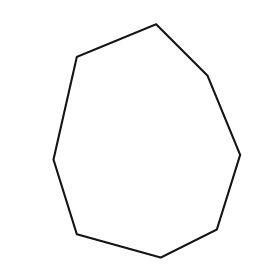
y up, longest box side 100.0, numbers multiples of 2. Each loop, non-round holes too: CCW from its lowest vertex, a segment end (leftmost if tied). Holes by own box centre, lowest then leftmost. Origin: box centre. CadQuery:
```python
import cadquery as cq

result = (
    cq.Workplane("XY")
    .moveTo(6.0, -50.0)
    .lineTo(30.0, -38.0)
    .lineTo(40.0, -6.0)
    .lineTo(26.0, 28.0)
    .lineTo(4.0, 50.0)
    .lineTo(-30.0, 36.0)
    .lineTo(-40.0, -8.0)
    .lineTo(-30.0, -40.0)
    .close()
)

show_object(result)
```